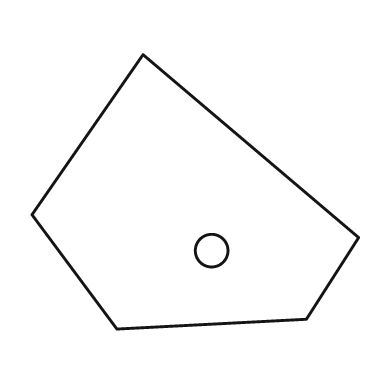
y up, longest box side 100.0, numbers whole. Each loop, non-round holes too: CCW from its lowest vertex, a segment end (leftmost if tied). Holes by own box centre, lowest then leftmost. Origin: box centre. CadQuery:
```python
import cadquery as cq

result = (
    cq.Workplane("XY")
    .moveTo(-24.0, -42.0)
    .lineTo(34.0, -39.0)
    .lineTo(50.0, -14.0)
    .lineTo(-16.0, 42.0)
    .lineTo(-50.0, -7.0)
    .close()
    .moveTo(5.0, -18.0)
    .circle(5.0)
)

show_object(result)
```